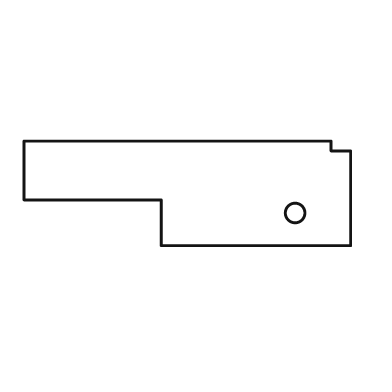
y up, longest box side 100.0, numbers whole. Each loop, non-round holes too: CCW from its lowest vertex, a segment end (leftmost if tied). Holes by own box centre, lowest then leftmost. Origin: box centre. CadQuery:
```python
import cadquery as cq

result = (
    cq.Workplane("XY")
    .moveTo(-8.0, -16.0)
    .lineTo(50.0, -16.0)
    .lineTo(50.0, 13.0)
    .lineTo(44.0, 13.0)
    .lineTo(44.0, 16.0)
    .lineTo(-50.0, 16.0)
    .lineTo(-50.0, -2.0)
    .lineTo(-8.0, -2.0)
    .close()
    .moveTo(33.0, -6.0)
    .circle(3.0)
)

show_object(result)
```